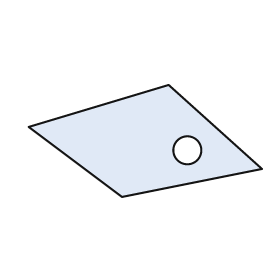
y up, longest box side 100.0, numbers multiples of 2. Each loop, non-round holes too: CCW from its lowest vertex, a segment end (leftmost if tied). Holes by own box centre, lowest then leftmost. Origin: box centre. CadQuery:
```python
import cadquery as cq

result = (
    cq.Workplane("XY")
    .moveTo(-10.0, -24.0)
    .lineTo(50.0, -12.0)
    .lineTo(10.0, 24.0)
    .lineTo(-50.0, 6.0)
    .close()
    .moveTo(18.0, -4.0)
    .circle(6.0)
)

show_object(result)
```